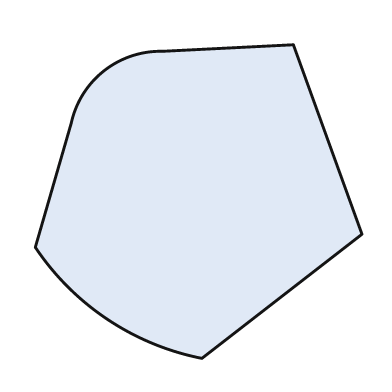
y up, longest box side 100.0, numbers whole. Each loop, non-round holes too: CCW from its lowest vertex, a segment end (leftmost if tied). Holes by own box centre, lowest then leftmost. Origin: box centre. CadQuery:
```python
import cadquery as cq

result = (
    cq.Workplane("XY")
    .moveTo(1.0, -48.0)
    .lineTo(50.0, -10.0)
    .lineTo(29.0, 48.0)
    .lineTo(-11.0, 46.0)
    .threePointArc((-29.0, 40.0), (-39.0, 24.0))
    .lineTo(-50.0, -14.0)
    .threePointArc((-28.0, -36.0), (1.0, -48.0))
    .close()
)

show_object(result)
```